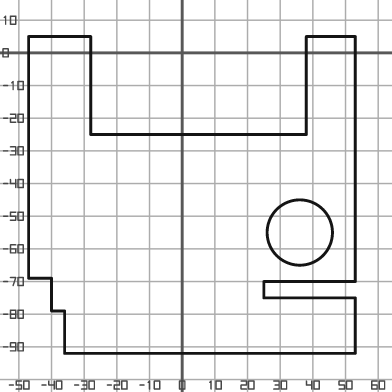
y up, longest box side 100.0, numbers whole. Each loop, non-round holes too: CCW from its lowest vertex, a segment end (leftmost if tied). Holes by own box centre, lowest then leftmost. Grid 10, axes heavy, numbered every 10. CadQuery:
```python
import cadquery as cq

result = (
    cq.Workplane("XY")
    .moveTo(-36.0, -92.0)
    .lineTo(53.0, -92.0)
    .lineTo(53.0, -75.0)
    .lineTo(25.0, -75.0)
    .lineTo(25.0, -70.0)
    .lineTo(53.0, -70.0)
    .lineTo(53.0, 5.0)
    .lineTo(38.0, 5.0)
    .lineTo(38.0, -25.0)
    .lineTo(-28.0, -25.0)
    .lineTo(-28.0, 5.0)
    .lineTo(-47.0, 5.0)
    .lineTo(-47.0, -69.0)
    .lineTo(-40.0, -69.0)
    .lineTo(-40.0, -79.0)
    .lineTo(-36.0, -79.0)
    .close()
    .moveTo(36.0, -55.0)
    .circle(10.0)
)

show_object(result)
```